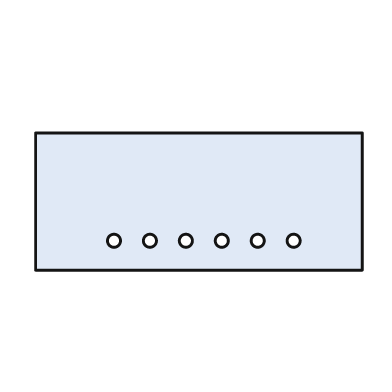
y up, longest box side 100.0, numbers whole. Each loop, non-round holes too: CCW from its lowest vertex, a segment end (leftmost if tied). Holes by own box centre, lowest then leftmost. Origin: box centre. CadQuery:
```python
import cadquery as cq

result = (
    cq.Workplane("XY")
    .moveTo(-50.0, -21.0)
    .lineTo(50.0, -21.0)
    .lineTo(50.0, 21.0)
    .lineTo(-50.0, 21.0)
    .close()
    .moveTo(-26.0, -12.0)
    .circle(2.0)
    .moveTo(-15.0, -12.0)
    .circle(2.0)
    .moveTo(-4.0, -12.0)
    .circle(2.0)
    .moveTo(7.0, -12.0)
    .circle(2.0)
    .moveTo(18.0, -12.0)
    .circle(2.0)
    .moveTo(29.0, -12.0)
    .circle(2.0)
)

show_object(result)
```